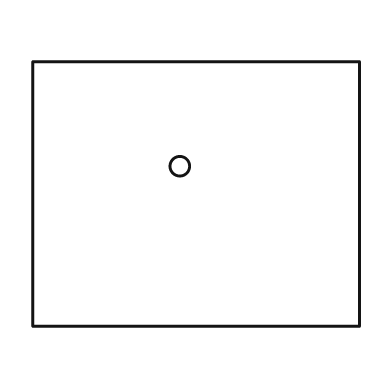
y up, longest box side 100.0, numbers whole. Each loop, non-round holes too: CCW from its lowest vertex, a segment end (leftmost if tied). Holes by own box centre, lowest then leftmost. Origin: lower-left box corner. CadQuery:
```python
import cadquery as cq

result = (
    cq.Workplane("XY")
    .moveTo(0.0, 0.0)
    .lineTo(100.0, 0.0)
    .lineTo(100.0, 81.0)
    .lineTo(0.0, 81.0)
    .close()
    .moveTo(45.0, 49.0)
    .circle(3.0)
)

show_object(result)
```